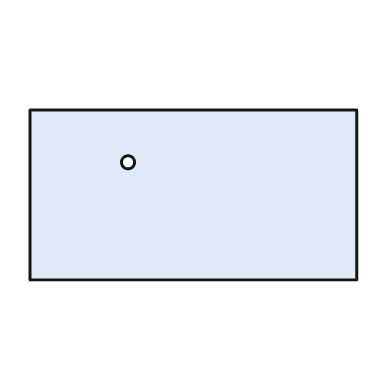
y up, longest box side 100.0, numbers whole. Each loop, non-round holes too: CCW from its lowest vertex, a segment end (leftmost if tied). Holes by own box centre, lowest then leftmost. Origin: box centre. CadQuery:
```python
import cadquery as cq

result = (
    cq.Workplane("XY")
    .moveTo(-50.0, -26.0)
    .lineTo(50.0, -26.0)
    .lineTo(50.0, 26.0)
    .lineTo(-50.0, 26.0)
    .close()
    .moveTo(-20.0, 10.0)
    .circle(2.0)
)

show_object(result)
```